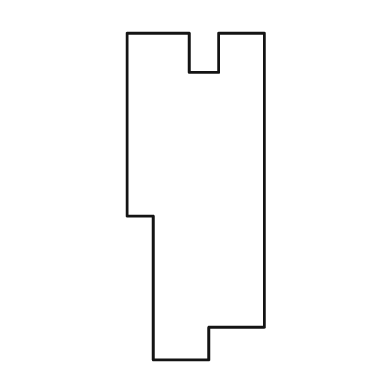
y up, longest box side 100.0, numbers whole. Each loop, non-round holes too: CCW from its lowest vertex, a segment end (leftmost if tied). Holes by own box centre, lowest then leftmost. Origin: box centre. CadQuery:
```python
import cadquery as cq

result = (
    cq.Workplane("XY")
    .moveTo(-13.0, -50.0)
    .lineTo(4.0, -50.0)
    .lineTo(4.0, -40.0)
    .lineTo(21.0, -40.0)
    .lineTo(21.0, 50.0)
    .lineTo(7.0, 50.0)
    .lineTo(7.0, 38.0)
    .lineTo(-2.0, 38.0)
    .lineTo(-2.0, 50.0)
    .lineTo(-21.0, 50.0)
    .lineTo(-21.0, -6.0)
    .lineTo(-13.0, -6.0)
    .close()
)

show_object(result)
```